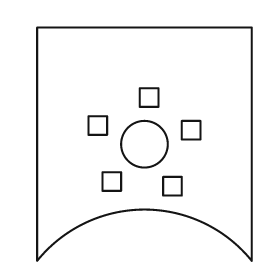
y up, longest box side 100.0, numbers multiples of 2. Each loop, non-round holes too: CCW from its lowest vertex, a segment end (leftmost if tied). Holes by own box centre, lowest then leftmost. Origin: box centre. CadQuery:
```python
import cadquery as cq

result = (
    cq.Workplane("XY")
    .moveTo(-46.0, -50.0)
    .threePointArc((0.0, -28.0), (46.0, -50.0))
    .lineTo(46.0, 50.0)
    .lineTo(-46.0, 50.0)
    .close()
    .moveTo(8.0, -22.0)
    .lineTo(16.0, -22.0)
    .lineTo(16.0, -14.0)
    .lineTo(8.0, -14.0)
    .close()
    .moveTo(-18.0, -20.0)
    .lineTo(-10.0, -20.0)
    .lineTo(-10.0, -12.0)
    .lineTo(-18.0, -12.0)
    .close()
    .moveTo(0.0, 0.0)
    .circle(10.0)
    .moveTo(16.0, 2.0)
    .lineTo(24.0, 2.0)
    .lineTo(24.0, 10.0)
    .lineTo(16.0, 10.0)
    .close()
    .moveTo(-24.0, 4.0)
    .lineTo(-16.0, 4.0)
    .lineTo(-16.0, 12.0)
    .lineTo(-24.0, 12.0)
    .close()
    .moveTo(-2.0, 16.0)
    .lineTo(6.0, 16.0)
    .lineTo(6.0, 24.0)
    .lineTo(-2.0, 24.0)
    .close()
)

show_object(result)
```